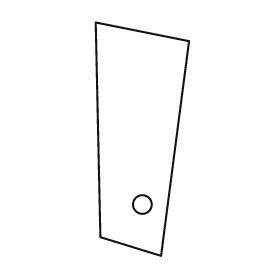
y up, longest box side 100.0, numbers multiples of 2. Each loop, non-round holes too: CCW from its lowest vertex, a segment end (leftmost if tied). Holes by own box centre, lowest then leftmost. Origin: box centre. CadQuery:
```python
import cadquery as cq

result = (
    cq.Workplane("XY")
    .moveTo(8.0, -50.0)
    .lineTo(20.0, 42.0)
    .lineTo(-20.0, 50.0)
    .lineTo(-18.0, -42.0)
    .close()
    .moveTo(0.0, -28.0)
    .circle(4.0)
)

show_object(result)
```